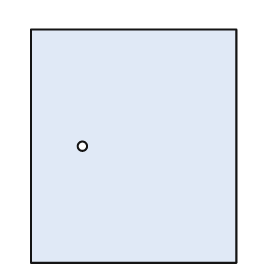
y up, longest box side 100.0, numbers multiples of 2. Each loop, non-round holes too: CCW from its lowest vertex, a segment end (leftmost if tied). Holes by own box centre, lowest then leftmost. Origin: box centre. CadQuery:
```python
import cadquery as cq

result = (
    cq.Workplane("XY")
    .moveTo(-44.0, -50.0)
    .lineTo(44.0, -50.0)
    .lineTo(44.0, 50.0)
    .lineTo(-44.0, 50.0)
    .close()
    .moveTo(-22.0, 0.0)
    .circle(2.0)
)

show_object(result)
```